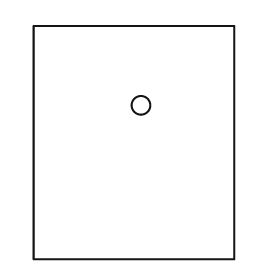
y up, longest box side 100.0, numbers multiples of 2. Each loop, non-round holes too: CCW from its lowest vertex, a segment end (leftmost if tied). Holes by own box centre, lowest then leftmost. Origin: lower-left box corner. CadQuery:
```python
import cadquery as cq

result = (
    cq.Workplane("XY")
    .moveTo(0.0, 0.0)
    .lineTo(86.0, 0.0)
    .lineTo(86.0, 100.0)
    .lineTo(0.0, 100.0)
    .close()
    .moveTo(46.0, 66.0)
    .circle(4.0)
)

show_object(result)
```